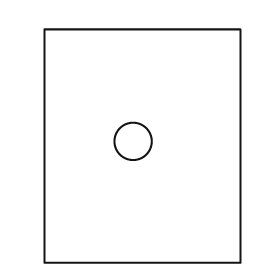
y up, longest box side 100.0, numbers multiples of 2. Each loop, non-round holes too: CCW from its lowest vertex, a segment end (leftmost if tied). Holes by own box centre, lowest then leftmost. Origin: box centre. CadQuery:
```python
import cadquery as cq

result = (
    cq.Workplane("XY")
    .moveTo(-42.0, -50.0)
    .lineTo(42.0, -50.0)
    .lineTo(42.0, 50.0)
    .lineTo(-42.0, 50.0)
    .close()
    .moveTo(-4.0, 2.0)
    .circle(8.0)
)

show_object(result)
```